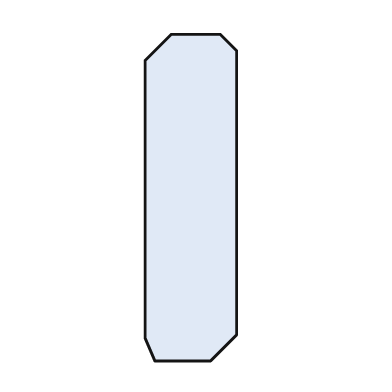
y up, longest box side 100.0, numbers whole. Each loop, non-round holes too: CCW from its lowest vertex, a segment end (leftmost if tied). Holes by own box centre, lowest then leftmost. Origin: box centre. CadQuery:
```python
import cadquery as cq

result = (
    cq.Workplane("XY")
    .moveTo(-11.0, -50.0)
    .lineTo(6.0, -50.0)
    .lineTo(14.0, -42.0)
    .lineTo(14.0, 45.0)
    .lineTo(9.0, 50.0)
    .lineTo(-6.0, 50.0)
    .lineTo(-14.0, 42.0)
    .lineTo(-14.0, -43.0)
    .close()
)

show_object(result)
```